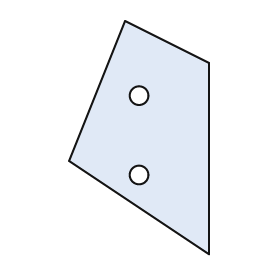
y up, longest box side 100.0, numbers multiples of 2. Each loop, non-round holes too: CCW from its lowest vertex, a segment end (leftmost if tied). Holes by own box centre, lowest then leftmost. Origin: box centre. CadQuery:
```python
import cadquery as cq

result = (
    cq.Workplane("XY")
    .moveTo(30.0, -50.0)
    .lineTo(30.0, 32.0)
    .lineTo(-6.0, 50.0)
    .lineTo(-30.0, -10.0)
    .close()
    .moveTo(0.0, -16.0)
    .circle(4.0)
    .moveTo(0.0, 18.0)
    .circle(4.0)
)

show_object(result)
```